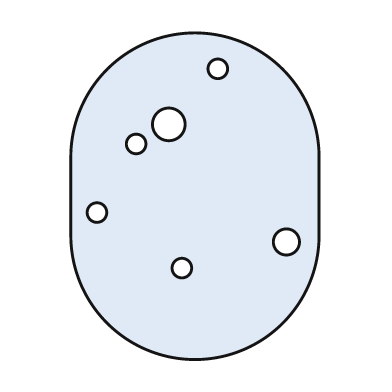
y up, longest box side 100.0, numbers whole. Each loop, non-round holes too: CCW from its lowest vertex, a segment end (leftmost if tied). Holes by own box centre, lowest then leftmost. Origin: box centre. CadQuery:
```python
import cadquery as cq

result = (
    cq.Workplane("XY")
    .moveTo(-38.0, -12.0)
    .threePointArc((0.0, -50.0), (38.0, -12.0))
    .lineTo(38.0, 12.0)
    .threePointArc((0.0, 50.0), (-38.0, 12.0))
    .close()
    .moveTo(-4.0, -22.0)
    .circle(3.0)
    .moveTo(28.0, -14.0)
    .circle(4.0)
    .moveTo(-30.0, -5.0)
    .circle(3.0)
    .moveTo(-18.0, 16.0)
    .circle(3.0)
    .moveTo(-8.0, 22.0)
    .circle(5.0)
    .moveTo(7.0, 39.0)
    .circle(3.0)
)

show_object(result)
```